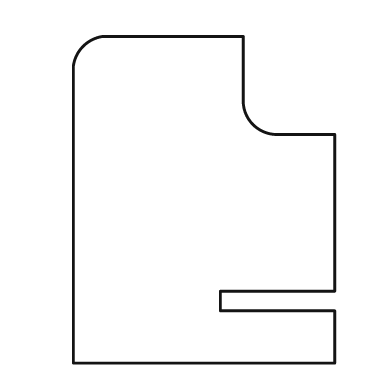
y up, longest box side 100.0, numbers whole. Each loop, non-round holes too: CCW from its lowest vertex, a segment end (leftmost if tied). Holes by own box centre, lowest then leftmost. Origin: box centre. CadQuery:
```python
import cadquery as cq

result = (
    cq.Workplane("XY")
    .moveTo(-40.0, -50.0)
    .lineTo(40.0, -50.0)
    .lineTo(40.0, -34.0)
    .lineTo(5.0, -34.0)
    .lineTo(5.0, -28.0)
    .lineTo(40.0, -28.0)
    .lineTo(40.0, 20.0)
    .lineTo(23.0, 20.0)
    .threePointArc((15.0, 23.0), (12.0, 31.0))
    .lineTo(12.0, 50.0)
    .lineTo(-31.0, 50.0)
    .threePointArc((-37.0, 47.0), (-40.0, 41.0))
    .close()
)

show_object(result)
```